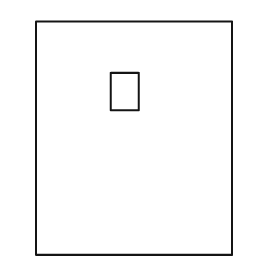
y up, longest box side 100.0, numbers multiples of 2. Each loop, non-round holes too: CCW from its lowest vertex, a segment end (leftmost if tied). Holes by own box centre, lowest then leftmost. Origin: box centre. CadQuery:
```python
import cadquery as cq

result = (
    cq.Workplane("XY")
    .moveTo(-42.0, -50.0)
    .lineTo(42.0, -50.0)
    .lineTo(42.0, 50.0)
    .lineTo(-42.0, 50.0)
    .close()
    .moveTo(-10.0, 12.0)
    .lineTo(2.0, 12.0)
    .lineTo(2.0, 28.0)
    .lineTo(-10.0, 28.0)
    .close()
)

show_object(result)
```